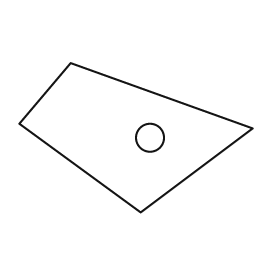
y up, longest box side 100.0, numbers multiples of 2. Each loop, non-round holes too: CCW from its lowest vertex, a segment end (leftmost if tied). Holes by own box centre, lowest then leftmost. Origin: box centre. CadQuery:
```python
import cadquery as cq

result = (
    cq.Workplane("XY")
    .moveTo(2.0, -32.0)
    .lineTo(50.0, 4.0)
    .lineTo(-28.0, 32.0)
    .lineTo(-50.0, 6.0)
    .close()
    .moveTo(6.0, 0.0)
    .circle(6.0)
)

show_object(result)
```